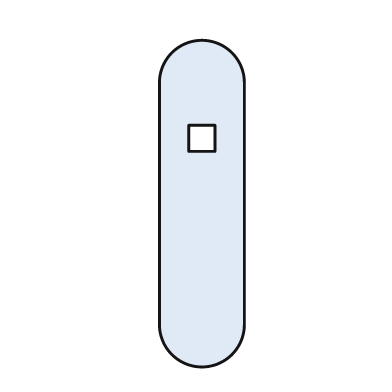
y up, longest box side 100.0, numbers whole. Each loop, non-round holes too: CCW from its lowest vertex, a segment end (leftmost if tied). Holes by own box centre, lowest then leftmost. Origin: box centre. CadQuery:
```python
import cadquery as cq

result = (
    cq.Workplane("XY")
    .moveTo(-13.0, -37.0)
    .threePointArc((0.0, -50.0), (13.0, -37.0))
    .lineTo(13.0, 37.0)
    .threePointArc((0.0, 50.0), (-13.0, 37.0))
    .close()
    .moveTo(-4.0, 16.0)
    .lineTo(4.0, 16.0)
    .lineTo(4.0, 24.0)
    .lineTo(-4.0, 24.0)
    .close()
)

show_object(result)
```